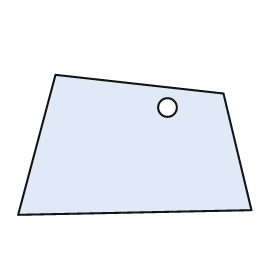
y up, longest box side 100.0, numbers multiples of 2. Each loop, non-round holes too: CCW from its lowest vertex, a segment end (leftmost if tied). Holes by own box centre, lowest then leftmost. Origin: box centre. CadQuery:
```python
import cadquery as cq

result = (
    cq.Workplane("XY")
    .moveTo(-50.0, -30.0)
    .lineTo(50.0, -28.0)
    .lineTo(38.0, 22.0)
    .lineTo(-34.0, 30.0)
    .close()
    .moveTo(14.0, 16.0)
    .circle(4.0)
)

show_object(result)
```